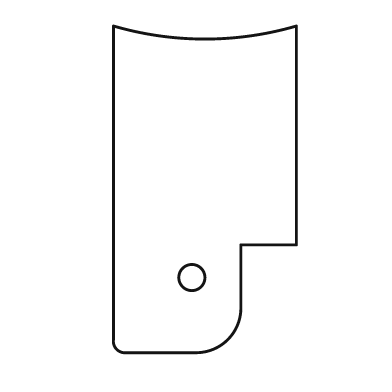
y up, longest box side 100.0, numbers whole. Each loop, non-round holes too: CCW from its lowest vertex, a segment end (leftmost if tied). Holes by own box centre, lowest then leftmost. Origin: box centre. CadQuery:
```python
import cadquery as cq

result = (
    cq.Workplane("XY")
    .moveTo(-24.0, -50.0)
    .lineTo(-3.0, -50.0)
    .threePointArc((7.0, -46.0), (11.0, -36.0))
    .lineTo(11.0, -17.0)
    .lineTo(28.0, -17.0)
    .lineTo(28.0, 50.0)
    .threePointArc((0.0, 46.0), (-28.0, 50.0))
    .lineTo(-28.0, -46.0)
    .threePointArc((-27.0, -49.0), (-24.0, -50.0))
    .close()
    .moveTo(-4.0, -27.0)
    .circle(4.0)
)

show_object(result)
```